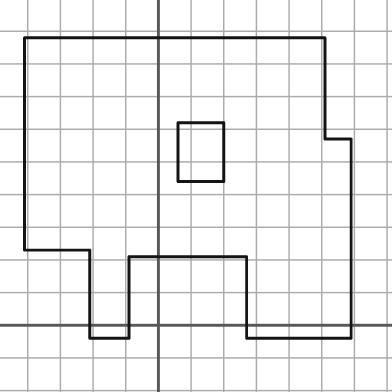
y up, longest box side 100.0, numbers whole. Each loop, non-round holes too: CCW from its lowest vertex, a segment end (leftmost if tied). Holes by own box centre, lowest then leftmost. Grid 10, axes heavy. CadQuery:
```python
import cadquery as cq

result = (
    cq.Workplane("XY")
    .moveTo(-21.0, -4.0)
    .lineTo(-9.0, -4.0)
    .lineTo(-9.0, 21.0)
    .lineTo(27.0, 21.0)
    .lineTo(27.0, -4.0)
    .lineTo(59.0, -4.0)
    .lineTo(59.0, 57.0)
    .lineTo(51.0, 57.0)
    .lineTo(51.0, 88.0)
    .lineTo(-41.0, 88.0)
    .lineTo(-41.0, 23.0)
    .lineTo(-21.0, 23.0)
    .close()
    .moveTo(6.0, 44.0)
    .lineTo(20.0, 44.0)
    .lineTo(20.0, 62.0)
    .lineTo(6.0, 62.0)
    .close()
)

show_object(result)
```